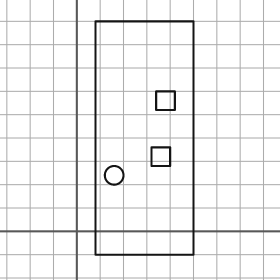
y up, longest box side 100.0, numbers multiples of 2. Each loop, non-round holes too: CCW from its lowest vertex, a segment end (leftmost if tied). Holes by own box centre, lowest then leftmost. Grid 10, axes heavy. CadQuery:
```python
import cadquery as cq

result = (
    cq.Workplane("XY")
    .moveTo(8.0, -10.0)
    .lineTo(50.0, -10.0)
    .lineTo(50.0, 90.0)
    .lineTo(8.0, 90.0)
    .close()
    .moveTo(16.0, 24.0)
    .circle(4.0)
    .moveTo(32.0, 28.0)
    .lineTo(40.0, 28.0)
    .lineTo(40.0, 36.0)
    .lineTo(32.0, 36.0)
    .close()
    .moveTo(34.0, 52.0)
    .lineTo(42.0, 52.0)
    .lineTo(42.0, 60.0)
    .lineTo(34.0, 60.0)
    .close()
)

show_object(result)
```